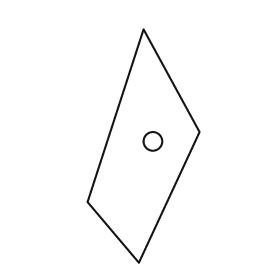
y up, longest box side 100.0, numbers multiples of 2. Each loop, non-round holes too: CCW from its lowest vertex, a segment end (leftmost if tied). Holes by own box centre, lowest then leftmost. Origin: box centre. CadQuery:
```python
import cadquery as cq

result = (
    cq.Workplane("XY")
    .moveTo(-2.0, -50.0)
    .lineTo(24.0, 6.0)
    .lineTo(0.0, 50.0)
    .lineTo(-24.0, -24.0)
    .close()
    .moveTo(4.0, 2.0)
    .circle(4.0)
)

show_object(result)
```